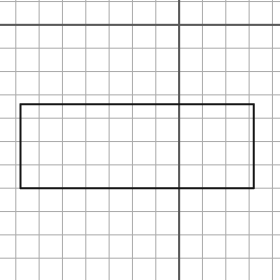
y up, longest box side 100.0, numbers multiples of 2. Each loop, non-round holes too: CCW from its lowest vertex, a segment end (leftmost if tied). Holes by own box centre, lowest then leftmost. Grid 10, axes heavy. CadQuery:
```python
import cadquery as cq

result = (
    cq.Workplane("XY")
    .moveTo(-68.0, -70.0)
    .lineTo(32.0, -70.0)
    .lineTo(32.0, -34.0)
    .lineTo(-68.0, -34.0)
    .close()
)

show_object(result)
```